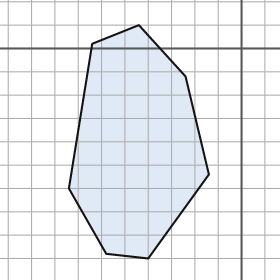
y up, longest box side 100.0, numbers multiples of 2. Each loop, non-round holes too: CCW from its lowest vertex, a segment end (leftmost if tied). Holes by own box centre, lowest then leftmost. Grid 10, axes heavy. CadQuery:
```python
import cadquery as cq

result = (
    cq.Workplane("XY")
    .moveTo(-40.0, -90.0)
    .lineTo(-14.0, -54.0)
    .lineTo(-24.0, -12.0)
    .lineTo(-44.0, 10.0)
    .lineTo(-64.0, 2.0)
    .lineTo(-74.0, -60.0)
    .lineTo(-58.0, -88.0)
    .close()
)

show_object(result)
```